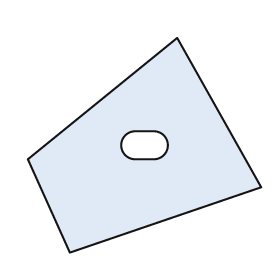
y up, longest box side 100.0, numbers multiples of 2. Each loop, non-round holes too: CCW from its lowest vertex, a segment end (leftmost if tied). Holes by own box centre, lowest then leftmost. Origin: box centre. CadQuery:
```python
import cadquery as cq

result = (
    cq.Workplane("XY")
    .moveTo(-32.0, -46.0)
    .lineTo(50.0, -18.0)
    .lineTo(14.0, 46.0)
    .lineTo(-50.0, -6.0)
    .close()
    .moveTo(-4.0, -6.0)
    .lineTo(4.0, -6.0)
    .threePointArc((10.0, 0.0), (4.0, 6.0))
    .lineTo(-4.0, 6.0)
    .threePointArc((-10.0, 0.0), (-4.0, -6.0))
    .close()
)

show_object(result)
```